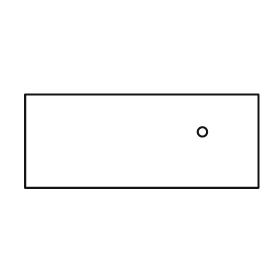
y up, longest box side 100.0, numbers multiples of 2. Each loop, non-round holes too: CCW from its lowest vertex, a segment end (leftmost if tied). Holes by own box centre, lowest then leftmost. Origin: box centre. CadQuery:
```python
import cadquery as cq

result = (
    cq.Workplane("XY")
    .moveTo(-50.0, -20.0)
    .lineTo(50.0, -20.0)
    .lineTo(50.0, 20.0)
    .lineTo(-50.0, 20.0)
    .close()
    .moveTo(26.0, 4.0)
    .circle(2.0)
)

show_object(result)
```